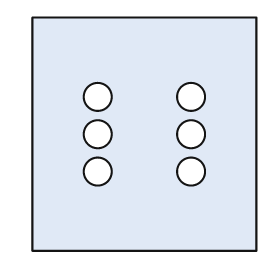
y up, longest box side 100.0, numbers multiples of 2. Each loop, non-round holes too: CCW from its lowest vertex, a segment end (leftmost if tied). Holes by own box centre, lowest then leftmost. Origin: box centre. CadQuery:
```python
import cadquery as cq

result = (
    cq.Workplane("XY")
    .moveTo(-48.0, -50.0)
    .lineTo(48.0, -50.0)
    .lineTo(48.0, 50.0)
    .lineTo(-48.0, 50.0)
    .close()
    .moveTo(-20.0, -16.0)
    .circle(6.0)
    .moveTo(20.0, -16.0)
    .circle(6.0)
    .moveTo(-20.0, 0.0)
    .circle(6.0)
    .moveTo(20.0, 0.0)
    .circle(6.0)
    .moveTo(-20.0, 16.0)
    .circle(6.0)
    .moveTo(20.0, 16.0)
    .circle(6.0)
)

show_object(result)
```